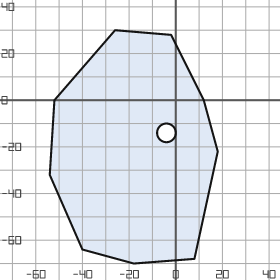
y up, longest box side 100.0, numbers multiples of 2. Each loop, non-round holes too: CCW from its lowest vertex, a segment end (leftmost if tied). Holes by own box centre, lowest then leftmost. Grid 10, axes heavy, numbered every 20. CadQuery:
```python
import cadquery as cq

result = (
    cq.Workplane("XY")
    .moveTo(-18.0, -70.0)
    .lineTo(8.0, -68.0)
    .lineTo(18.0, -22.0)
    .lineTo(12.0, 0.0)
    .lineTo(-2.0, 28.0)
    .lineTo(-26.0, 30.0)
    .lineTo(-52.0, 0.0)
    .lineTo(-54.0, -32.0)
    .lineTo(-40.0, -64.0)
    .close()
    .moveTo(-4.0, -14.0)
    .circle(4.0)
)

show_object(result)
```